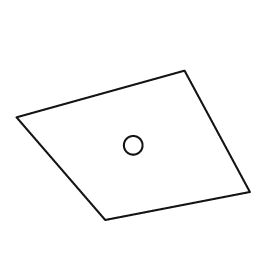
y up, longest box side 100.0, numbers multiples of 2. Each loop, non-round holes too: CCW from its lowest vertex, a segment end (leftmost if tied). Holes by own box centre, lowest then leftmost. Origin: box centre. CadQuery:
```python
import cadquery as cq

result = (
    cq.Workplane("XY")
    .moveTo(-12.0, -32.0)
    .lineTo(50.0, -20.0)
    .lineTo(22.0, 32.0)
    .lineTo(-50.0, 12.0)
    .close()
    .moveTo(0.0, 0.0)
    .circle(4.0)
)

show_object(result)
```